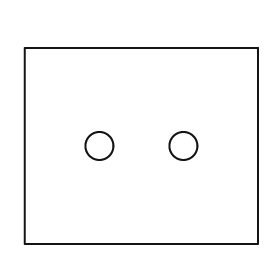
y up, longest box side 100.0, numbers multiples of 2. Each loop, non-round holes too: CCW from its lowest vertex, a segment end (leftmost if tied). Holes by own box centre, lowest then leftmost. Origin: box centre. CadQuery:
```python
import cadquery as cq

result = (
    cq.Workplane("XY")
    .moveTo(-50.0, -42.0)
    .lineTo(50.0, -42.0)
    .lineTo(50.0, 42.0)
    .lineTo(-50.0, 42.0)
    .close()
    .moveTo(-18.0, 0.0)
    .circle(6.0)
    .moveTo(18.0, 0.0)
    .circle(6.0)
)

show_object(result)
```